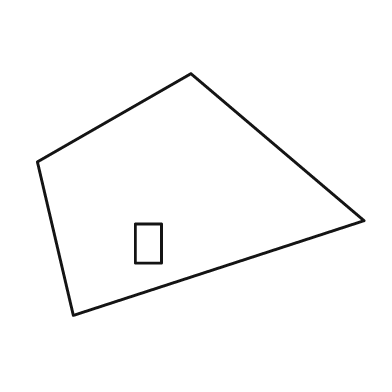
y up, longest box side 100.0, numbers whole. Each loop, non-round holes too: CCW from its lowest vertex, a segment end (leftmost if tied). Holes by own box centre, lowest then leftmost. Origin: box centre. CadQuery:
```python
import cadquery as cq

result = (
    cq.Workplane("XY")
    .moveTo(-39.0, -37.0)
    .lineTo(50.0, -8.0)
    .lineTo(-3.0, 37.0)
    .lineTo(-50.0, 10.0)
    .close()
    .moveTo(-20.0, -21.0)
    .lineTo(-12.0, -21.0)
    .lineTo(-12.0, -9.0)
    .lineTo(-20.0, -9.0)
    .close()
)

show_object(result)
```